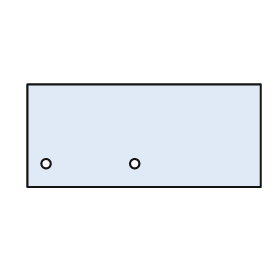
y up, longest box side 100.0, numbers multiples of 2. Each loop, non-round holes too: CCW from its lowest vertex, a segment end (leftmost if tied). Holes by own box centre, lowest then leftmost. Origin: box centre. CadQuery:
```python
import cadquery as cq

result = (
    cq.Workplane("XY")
    .moveTo(-50.0, -22.0)
    .lineTo(50.0, -22.0)
    .lineTo(50.0, 22.0)
    .lineTo(-50.0, 22.0)
    .close()
    .moveTo(-42.0, -12.0)
    .circle(2.0)
    .moveTo(-4.0, -12.0)
    .circle(2.0)
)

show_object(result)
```